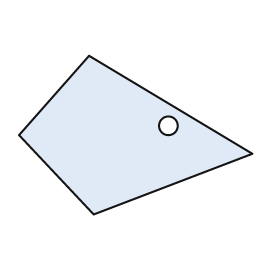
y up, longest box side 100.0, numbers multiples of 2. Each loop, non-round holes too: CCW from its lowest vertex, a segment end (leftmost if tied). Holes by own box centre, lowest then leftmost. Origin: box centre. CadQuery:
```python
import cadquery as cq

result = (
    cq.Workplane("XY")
    .moveTo(-18.0, -34.0)
    .lineTo(50.0, -8.0)
    .lineTo(-20.0, 34.0)
    .lineTo(-50.0, 0.0)
    .close()
    .moveTo(14.0, 4.0)
    .circle(4.0)
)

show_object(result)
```